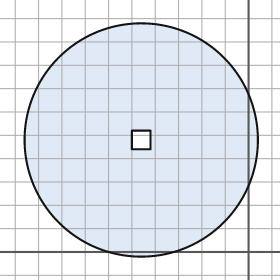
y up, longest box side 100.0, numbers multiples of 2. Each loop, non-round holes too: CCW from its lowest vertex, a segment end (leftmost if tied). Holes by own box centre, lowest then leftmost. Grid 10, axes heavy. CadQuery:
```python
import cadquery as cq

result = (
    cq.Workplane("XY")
    .moveTo(-46.0, 48.0)
    .circle(50.0)
    .moveTo(-50.0, 44.0)
    .lineTo(-42.0, 44.0)
    .lineTo(-42.0, 52.0)
    .lineTo(-50.0, 52.0)
    .close()
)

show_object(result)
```